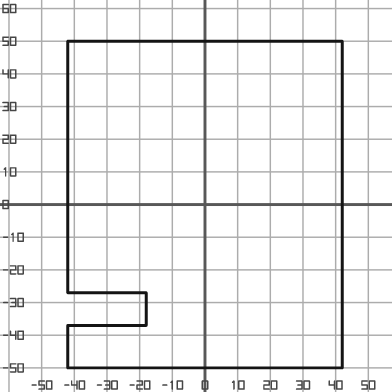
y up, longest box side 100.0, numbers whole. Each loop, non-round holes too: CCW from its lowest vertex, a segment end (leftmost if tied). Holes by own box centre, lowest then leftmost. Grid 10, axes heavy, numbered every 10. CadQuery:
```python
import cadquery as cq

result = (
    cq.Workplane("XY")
    .moveTo(-42.0, -50.0)
    .lineTo(42.0, -50.0)
    .lineTo(42.0, 50.0)
    .lineTo(-42.0, 50.0)
    .lineTo(-42.0, -27.0)
    .lineTo(-18.0, -27.0)
    .lineTo(-18.0, -37.0)
    .lineTo(-42.0, -37.0)
    .close()
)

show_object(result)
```